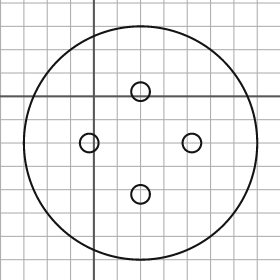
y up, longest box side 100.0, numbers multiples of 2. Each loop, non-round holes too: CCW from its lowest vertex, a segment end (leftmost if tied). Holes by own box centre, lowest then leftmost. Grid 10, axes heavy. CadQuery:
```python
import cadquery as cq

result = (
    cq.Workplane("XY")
    .moveTo(20.0, -20.0)
    .circle(50.0)
    .moveTo(20.0, -42.0)
    .circle(4.0)
    .moveTo(-2.0, -20.0)
    .circle(4.0)
    .moveTo(42.0, -20.0)
    .circle(4.0)
    .moveTo(20.0, 2.0)
    .circle(4.0)
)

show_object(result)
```